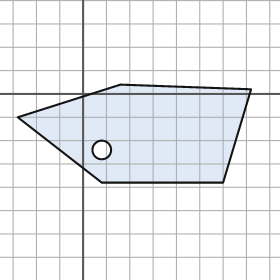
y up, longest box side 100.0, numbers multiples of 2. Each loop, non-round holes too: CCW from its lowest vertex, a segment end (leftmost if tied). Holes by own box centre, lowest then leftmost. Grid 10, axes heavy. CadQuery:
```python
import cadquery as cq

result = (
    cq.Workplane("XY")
    .moveTo(8.0, -38.0)
    .lineTo(60.0, -38.0)
    .lineTo(72.0, 2.0)
    .lineTo(16.0, 4.0)
    .lineTo(-28.0, -10.0)
    .close()
    .moveTo(8.0, -24.0)
    .circle(4.0)
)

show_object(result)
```